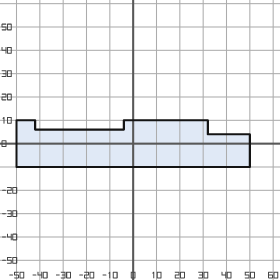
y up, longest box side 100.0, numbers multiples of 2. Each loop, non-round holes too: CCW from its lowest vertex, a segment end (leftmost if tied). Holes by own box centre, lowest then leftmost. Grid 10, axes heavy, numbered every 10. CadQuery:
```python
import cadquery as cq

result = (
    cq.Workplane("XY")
    .moveTo(-50.0, -10.0)
    .lineTo(50.0, -10.0)
    .lineTo(50.0, 4.0)
    .lineTo(32.0, 4.0)
    .lineTo(32.0, 10.0)
    .lineTo(-4.0, 10.0)
    .lineTo(-4.0, 6.0)
    .lineTo(-42.0, 6.0)
    .lineTo(-42.0, 10.0)
    .lineTo(-50.0, 10.0)
    .close()
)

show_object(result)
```